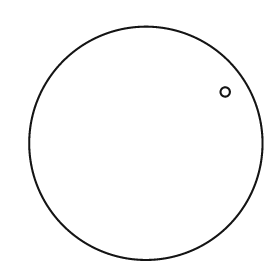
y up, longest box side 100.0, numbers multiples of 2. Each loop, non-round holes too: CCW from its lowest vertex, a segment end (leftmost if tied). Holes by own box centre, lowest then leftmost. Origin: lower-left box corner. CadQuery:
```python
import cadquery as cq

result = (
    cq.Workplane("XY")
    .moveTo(50.0, 50.0)
    .circle(50.0)
    .moveTo(84.0, 72.0)
    .circle(2.0)
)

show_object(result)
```